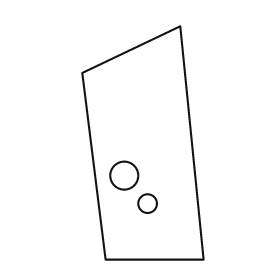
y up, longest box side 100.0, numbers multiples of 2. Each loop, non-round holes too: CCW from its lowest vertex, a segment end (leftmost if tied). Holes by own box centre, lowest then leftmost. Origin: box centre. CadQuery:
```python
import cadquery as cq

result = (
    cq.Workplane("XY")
    .moveTo(-16.0, -50.0)
    .lineTo(26.0, -50.0)
    .lineTo(16.0, 50.0)
    .lineTo(-26.0, 30.0)
    .close()
    .moveTo(2.0, -26.0)
    .circle(4.0)
    .moveTo(-8.0, -14.0)
    .circle(6.0)
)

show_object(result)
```